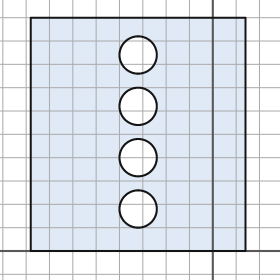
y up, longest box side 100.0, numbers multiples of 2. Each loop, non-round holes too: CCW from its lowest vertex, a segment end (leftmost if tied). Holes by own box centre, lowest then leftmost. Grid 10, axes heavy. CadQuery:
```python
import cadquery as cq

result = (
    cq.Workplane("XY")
    .moveTo(-78.0, 0.0)
    .lineTo(14.0, 0.0)
    .lineTo(14.0, 100.0)
    .lineTo(-78.0, 100.0)
    .close()
    .moveTo(-32.0, 18.0)
    .circle(8.0)
    .moveTo(-32.0, 40.0)
    .circle(8.0)
    .moveTo(-32.0, 62.0)
    .circle(8.0)
    .moveTo(-32.0, 84.0)
    .circle(8.0)
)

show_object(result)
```